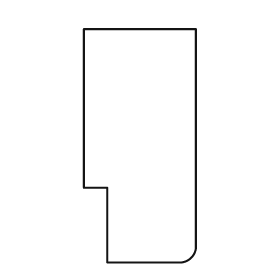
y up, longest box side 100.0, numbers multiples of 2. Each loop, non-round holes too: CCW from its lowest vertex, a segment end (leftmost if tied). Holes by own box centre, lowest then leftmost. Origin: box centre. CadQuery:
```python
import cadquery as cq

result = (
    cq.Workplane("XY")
    .moveTo(-14.0, -50.0)
    .lineTo(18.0, -50.0)
    .threePointArc((22.0, -48.0), (24.0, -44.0))
    .lineTo(24.0, 50.0)
    .lineTo(-24.0, 50.0)
    .lineTo(-24.0, -18.0)
    .lineTo(-14.0, -18.0)
    .close()
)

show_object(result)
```